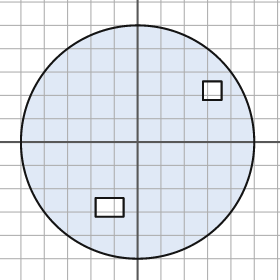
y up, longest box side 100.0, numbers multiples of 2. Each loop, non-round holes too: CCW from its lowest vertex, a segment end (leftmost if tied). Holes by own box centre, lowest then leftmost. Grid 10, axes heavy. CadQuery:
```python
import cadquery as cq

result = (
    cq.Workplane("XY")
    .moveTo(0.0, 0.0)
    .circle(50.0)
    .moveTo(-18.0, -32.0)
    .lineTo(-6.0, -32.0)
    .lineTo(-6.0, -24.0)
    .lineTo(-18.0, -24.0)
    .close()
    .moveTo(28.0, 18.0)
    .lineTo(36.0, 18.0)
    .lineTo(36.0, 26.0)
    .lineTo(28.0, 26.0)
    .close()
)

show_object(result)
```